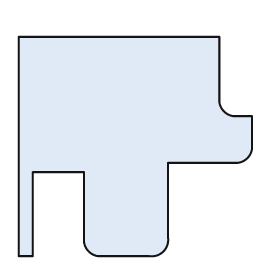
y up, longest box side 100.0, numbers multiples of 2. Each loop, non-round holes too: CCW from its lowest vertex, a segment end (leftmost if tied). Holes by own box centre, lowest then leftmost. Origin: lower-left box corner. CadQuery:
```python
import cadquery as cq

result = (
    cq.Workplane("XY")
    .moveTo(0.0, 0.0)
    .lineTo(6.0, 0.0)
    .lineTo(6.0, 36.0)
    .lineTo(28.0, 36.0)
    .lineTo(28.0, 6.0)
    .threePointArc((30.0, 2.0), (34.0, 0.0))
    .lineTo(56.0, 0.0)
    .threePointArc((62.0, 2.0), (64.0, 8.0))
    .lineTo(64.0, 40.0)
    .lineTo(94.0, 40.0)
    .threePointArc((98.0, 42.0), (100.0, 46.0))
    .lineTo(100.0, 60.0)
    .lineTo(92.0, 60.0)
    .threePointArc((88.0, 62.0), (86.0, 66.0))
    .lineTo(86.0, 94.0)
    .lineTo(0.0, 94.0)
    .close()
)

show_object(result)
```